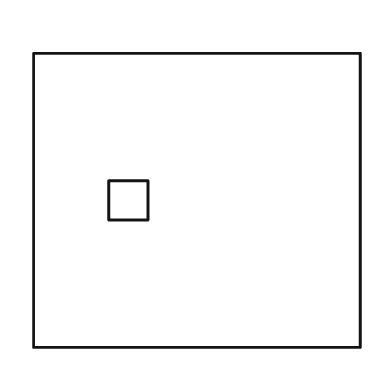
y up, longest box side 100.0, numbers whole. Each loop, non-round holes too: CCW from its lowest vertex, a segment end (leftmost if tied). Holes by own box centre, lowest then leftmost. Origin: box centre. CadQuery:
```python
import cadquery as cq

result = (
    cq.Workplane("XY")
    .moveTo(-50.0, -45.0)
    .lineTo(50.0, -45.0)
    .lineTo(50.0, 45.0)
    .lineTo(-50.0, 45.0)
    .close()
    .moveTo(-27.0, -6.0)
    .lineTo(-15.0, -6.0)
    .lineTo(-15.0, 6.0)
    .lineTo(-27.0, 6.0)
    .close()
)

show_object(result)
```